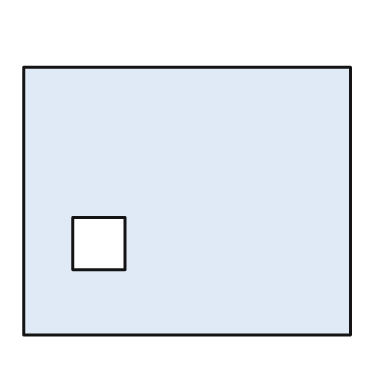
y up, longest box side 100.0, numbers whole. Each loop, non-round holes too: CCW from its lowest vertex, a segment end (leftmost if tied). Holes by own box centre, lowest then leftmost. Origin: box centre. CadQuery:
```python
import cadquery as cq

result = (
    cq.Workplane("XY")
    .moveTo(-50.0, -41.0)
    .lineTo(50.0, -41.0)
    .lineTo(50.0, 41.0)
    .lineTo(-50.0, 41.0)
    .close()
    .moveTo(-35.0, -21.0)
    .lineTo(-19.0, -21.0)
    .lineTo(-19.0, -5.0)
    .lineTo(-35.0, -5.0)
    .close()
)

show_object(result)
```